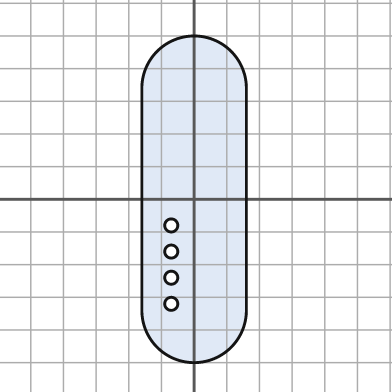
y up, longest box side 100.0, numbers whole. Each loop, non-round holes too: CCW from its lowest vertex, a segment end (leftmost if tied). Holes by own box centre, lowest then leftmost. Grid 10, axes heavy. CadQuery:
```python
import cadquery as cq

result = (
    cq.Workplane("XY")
    .moveTo(-16.0, -34.0)
    .threePointArc((0.0, -50.0), (16.0, -34.0))
    .lineTo(16.0, 34.0)
    .threePointArc((0.0, 50.0), (-16.0, 34.0))
    .close()
    .moveTo(-7.0, -32.0)
    .circle(2.0)
    .moveTo(-7.0, -24.0)
    .circle(2.0)
    .moveTo(-7.0, -16.0)
    .circle(2.0)
    .moveTo(-7.0, -8.0)
    .circle(2.0)
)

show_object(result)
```